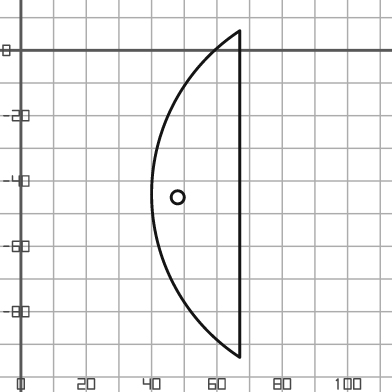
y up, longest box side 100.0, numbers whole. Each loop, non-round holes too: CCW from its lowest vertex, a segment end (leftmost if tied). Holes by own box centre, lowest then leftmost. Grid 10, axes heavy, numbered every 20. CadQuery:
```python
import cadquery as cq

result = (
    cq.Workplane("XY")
    .moveTo(67.0, -94.0)
    .lineTo(67.0, 6.0)
    .threePointArc((40.0, -44.0), (67.0, -94.0))
    .close()
    .moveTo(48.0, -45.0)
    .circle(2.0)
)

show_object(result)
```